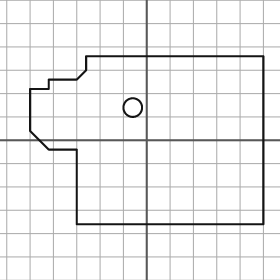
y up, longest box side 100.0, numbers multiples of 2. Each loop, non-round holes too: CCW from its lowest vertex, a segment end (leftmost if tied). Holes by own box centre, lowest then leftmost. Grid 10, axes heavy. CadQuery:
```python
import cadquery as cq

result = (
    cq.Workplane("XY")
    .moveTo(-30.0, -36.0)
    .lineTo(50.0, -36.0)
    .lineTo(50.0, 36.0)
    .lineTo(-26.0, 36.0)
    .lineTo(-26.0, 30.0)
    .lineTo(-30.0, 26.0)
    .lineTo(-42.0, 26.0)
    .lineTo(-42.0, 22.0)
    .lineTo(-50.0, 22.0)
    .lineTo(-50.0, 4.0)
    .lineTo(-42.0, -4.0)
    .lineTo(-30.0, -4.0)
    .close()
    .moveTo(-6.0, 14.0)
    .circle(4.0)
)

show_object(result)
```